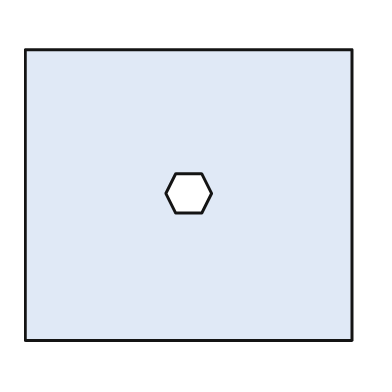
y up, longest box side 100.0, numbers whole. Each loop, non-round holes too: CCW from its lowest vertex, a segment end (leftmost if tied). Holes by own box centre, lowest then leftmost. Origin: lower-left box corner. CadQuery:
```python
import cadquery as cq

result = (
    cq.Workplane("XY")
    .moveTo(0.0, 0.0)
    .lineTo(100.0, 0.0)
    .lineTo(100.0, 89.0)
    .lineTo(0.0, 89.0)
    .close()
    .moveTo(46.0, 39.0)
    .lineTo(54.0, 39.0)
    .lineTo(57.0, 45.0)
    .lineTo(54.0, 51.0)
    .lineTo(46.0, 51.0)
    .lineTo(43.0, 45.0)
    .close()
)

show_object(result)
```